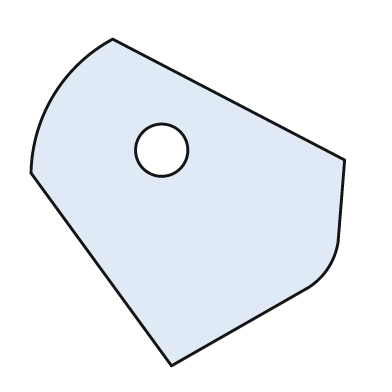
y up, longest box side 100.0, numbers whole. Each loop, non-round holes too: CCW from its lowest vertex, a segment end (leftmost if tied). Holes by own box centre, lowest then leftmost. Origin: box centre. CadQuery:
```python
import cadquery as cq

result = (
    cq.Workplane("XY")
    .moveTo(-5.0, -50.0)
    .lineTo(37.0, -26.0)
    .threePointArc((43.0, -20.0), (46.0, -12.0))
    .lineTo(48.0, 13.0)
    .lineTo(-23.0, 50.0)
    .threePointArc((-41.0, 33.0), (-48.0, 9.0))
    .close()
    .moveTo(-8.0, 16.0)
    .circle(8.0)
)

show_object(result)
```